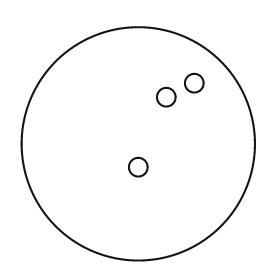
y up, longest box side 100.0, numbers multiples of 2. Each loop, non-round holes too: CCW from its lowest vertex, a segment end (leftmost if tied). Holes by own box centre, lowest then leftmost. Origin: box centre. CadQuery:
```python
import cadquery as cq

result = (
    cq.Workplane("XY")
    .moveTo(0.0, 0.0)
    .circle(50.0)
    .moveTo(0.0, -10.0)
    .circle(4.0)
    .moveTo(12.0, 20.0)
    .circle(4.0)
    .moveTo(24.0, 26.0)
    .circle(4.0)
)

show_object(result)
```